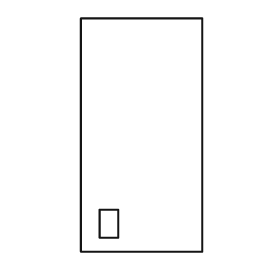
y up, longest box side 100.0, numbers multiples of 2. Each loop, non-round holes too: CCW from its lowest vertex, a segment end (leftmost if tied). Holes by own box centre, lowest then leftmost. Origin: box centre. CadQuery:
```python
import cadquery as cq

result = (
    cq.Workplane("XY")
    .moveTo(-26.0, -50.0)
    .lineTo(26.0, -50.0)
    .lineTo(26.0, 50.0)
    .lineTo(-26.0, 50.0)
    .close()
    .moveTo(-18.0, -44.0)
    .lineTo(-10.0, -44.0)
    .lineTo(-10.0, -32.0)
    .lineTo(-18.0, -32.0)
    .close()
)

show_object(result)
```